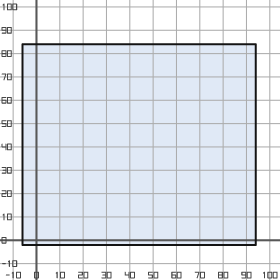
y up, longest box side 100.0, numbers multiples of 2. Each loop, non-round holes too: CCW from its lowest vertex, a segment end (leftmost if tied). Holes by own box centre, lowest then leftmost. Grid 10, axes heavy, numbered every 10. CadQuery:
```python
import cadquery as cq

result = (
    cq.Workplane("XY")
    .moveTo(-6.0, -2.0)
    .lineTo(94.0, -2.0)
    .lineTo(94.0, 84.0)
    .lineTo(-6.0, 84.0)
    .close()
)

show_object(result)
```